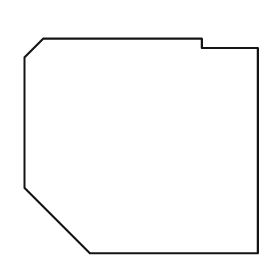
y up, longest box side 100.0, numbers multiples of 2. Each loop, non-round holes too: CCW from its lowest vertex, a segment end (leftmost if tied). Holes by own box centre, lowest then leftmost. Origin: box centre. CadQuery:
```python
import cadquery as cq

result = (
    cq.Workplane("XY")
    .moveTo(-22.0, -46.0)
    .lineTo(50.0, -46.0)
    .lineTo(50.0, 42.0)
    .lineTo(26.0, 42.0)
    .lineTo(26.0, 46.0)
    .lineTo(-42.0, 46.0)
    .lineTo(-50.0, 38.0)
    .lineTo(-50.0, -18.0)
    .close()
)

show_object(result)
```